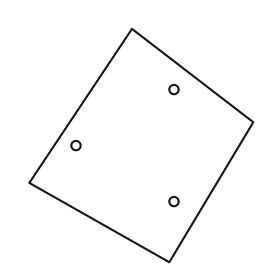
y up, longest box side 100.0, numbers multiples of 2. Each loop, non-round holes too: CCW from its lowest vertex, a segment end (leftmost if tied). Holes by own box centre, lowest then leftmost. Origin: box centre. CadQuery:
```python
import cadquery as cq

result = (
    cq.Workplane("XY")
    .moveTo(12.0, -50.0)
    .lineTo(48.0, 10.0)
    .lineTo(-4.0, 50.0)
    .lineTo(-48.0, -16.0)
    .close()
    .moveTo(14.0, -24.0)
    .circle(2.0)
    .moveTo(-28.0, 0.0)
    .circle(2.0)
    .moveTo(14.0, 24.0)
    .circle(2.0)
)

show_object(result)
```